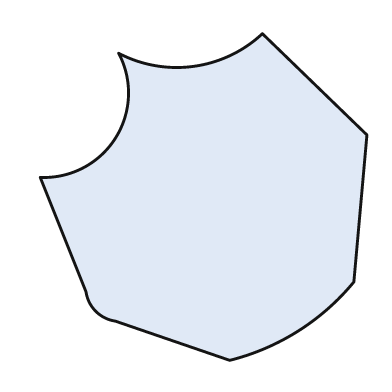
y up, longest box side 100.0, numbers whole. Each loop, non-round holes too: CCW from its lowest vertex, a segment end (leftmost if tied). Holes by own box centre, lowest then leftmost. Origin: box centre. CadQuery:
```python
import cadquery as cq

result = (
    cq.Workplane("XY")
    .moveTo(8.0, -50.0)
    .threePointArc((29.0, -41.0), (46.0, -26.0))
    .lineTo(50.0, 19.0)
    .lineTo(18.0, 50.0)
    .threePointArc((-3.0, 40.0), (-26.0, 44.0))
    .threePointArc((-27.0, 18.0), (-50.0, 6.0))
    .lineTo(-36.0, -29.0)
    .threePointArc((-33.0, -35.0), (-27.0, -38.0))
    .close()
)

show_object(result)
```